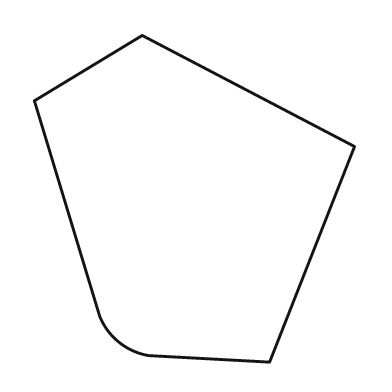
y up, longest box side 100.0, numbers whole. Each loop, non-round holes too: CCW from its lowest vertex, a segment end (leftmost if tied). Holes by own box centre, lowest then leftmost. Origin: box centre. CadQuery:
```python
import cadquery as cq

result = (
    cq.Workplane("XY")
    .moveTo(23.0, -50.0)
    .lineTo(49.0, 16.0)
    .lineTo(-16.0, 50.0)
    .lineTo(-49.0, 30.0)
    .lineTo(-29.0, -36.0)
    .threePointArc((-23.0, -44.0), (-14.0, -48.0))
    .close()
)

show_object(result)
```